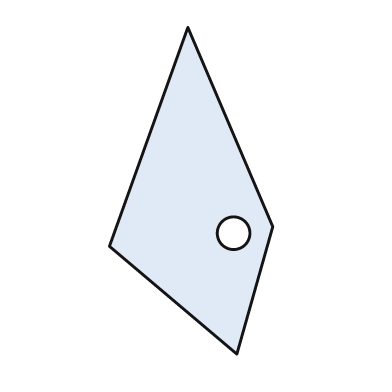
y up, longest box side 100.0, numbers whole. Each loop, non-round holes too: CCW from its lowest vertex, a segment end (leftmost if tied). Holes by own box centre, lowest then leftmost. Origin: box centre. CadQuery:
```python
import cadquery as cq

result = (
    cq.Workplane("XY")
    .moveTo(14.0, -50.0)
    .lineTo(25.0, -11.0)
    .lineTo(-1.0, 50.0)
    .lineTo(-25.0, -17.0)
    .close()
    .moveTo(13.0, -13.0)
    .circle(5.0)
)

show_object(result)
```